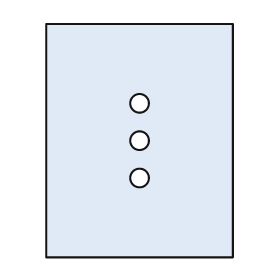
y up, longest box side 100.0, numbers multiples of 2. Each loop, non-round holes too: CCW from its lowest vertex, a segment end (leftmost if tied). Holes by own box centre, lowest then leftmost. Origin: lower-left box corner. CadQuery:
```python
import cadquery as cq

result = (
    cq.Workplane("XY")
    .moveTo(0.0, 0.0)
    .lineTo(80.0, 0.0)
    .lineTo(80.0, 100.0)
    .lineTo(0.0, 100.0)
    .close()
    .moveTo(40.0, 34.0)
    .circle(4.0)
    .moveTo(40.0, 50.0)
    .circle(4.0)
    .moveTo(40.0, 66.0)
    .circle(4.0)
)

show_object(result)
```